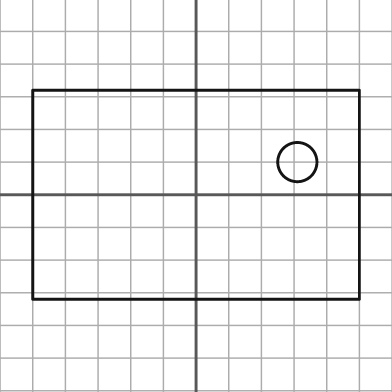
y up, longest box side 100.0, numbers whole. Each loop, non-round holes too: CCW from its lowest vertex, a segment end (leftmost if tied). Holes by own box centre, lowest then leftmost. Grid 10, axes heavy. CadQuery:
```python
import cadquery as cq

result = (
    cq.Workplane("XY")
    .moveTo(-50.0, -32.0)
    .lineTo(50.0, -32.0)
    .lineTo(50.0, 32.0)
    .lineTo(-50.0, 32.0)
    .close()
    .moveTo(31.0, 10.0)
    .circle(6.0)
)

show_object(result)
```